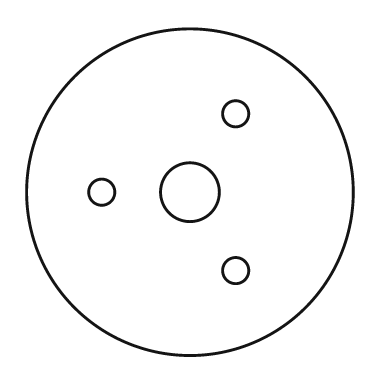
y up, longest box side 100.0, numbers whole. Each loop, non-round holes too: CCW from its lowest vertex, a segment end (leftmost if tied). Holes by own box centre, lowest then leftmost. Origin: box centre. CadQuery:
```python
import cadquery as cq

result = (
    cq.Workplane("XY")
    .moveTo(0.0, 0.0)
    .circle(50.0)
    .moveTo(14.0, -24.0)
    .circle(4.0)
    .moveTo(-27.0, 0.0)
    .circle(4.0)
    .moveTo(0.0, 0.0)
    .circle(9.0)
    .moveTo(14.0, 24.0)
    .circle(4.0)
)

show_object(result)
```